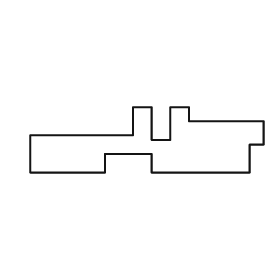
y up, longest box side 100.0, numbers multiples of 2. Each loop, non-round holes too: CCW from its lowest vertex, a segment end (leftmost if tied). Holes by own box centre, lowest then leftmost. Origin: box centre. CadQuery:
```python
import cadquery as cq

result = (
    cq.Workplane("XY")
    .moveTo(-50.0, -14.0)
    .lineTo(-18.0, -14.0)
    .lineTo(-18.0, -6.0)
    .lineTo(2.0, -6.0)
    .lineTo(2.0, -14.0)
    .lineTo(44.0, -14.0)
    .lineTo(44.0, -2.0)
    .lineTo(50.0, -2.0)
    .lineTo(50.0, 8.0)
    .lineTo(18.0, 8.0)
    .lineTo(18.0, 14.0)
    .lineTo(10.0, 14.0)
    .lineTo(10.0, 0.0)
    .lineTo(2.0, 0.0)
    .lineTo(2.0, 14.0)
    .lineTo(-6.0, 14.0)
    .lineTo(-6.0, 2.0)
    .lineTo(-50.0, 2.0)
    .close()
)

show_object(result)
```